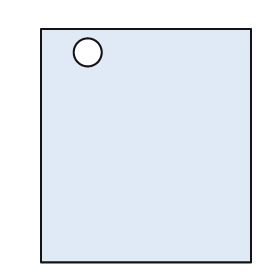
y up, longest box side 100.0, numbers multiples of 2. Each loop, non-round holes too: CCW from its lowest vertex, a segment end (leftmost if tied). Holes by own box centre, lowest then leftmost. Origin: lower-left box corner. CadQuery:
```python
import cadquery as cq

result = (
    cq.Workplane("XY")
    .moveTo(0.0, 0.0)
    .lineTo(90.0, 0.0)
    .lineTo(90.0, 100.0)
    .lineTo(0.0, 100.0)
    .close()
    .moveTo(20.0, 90.0)
    .circle(6.0)
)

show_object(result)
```